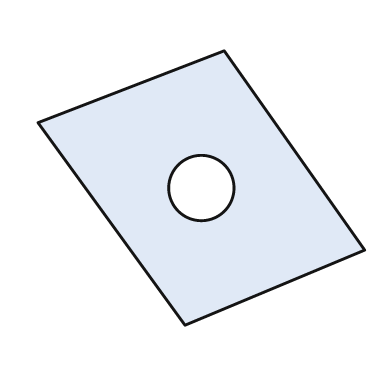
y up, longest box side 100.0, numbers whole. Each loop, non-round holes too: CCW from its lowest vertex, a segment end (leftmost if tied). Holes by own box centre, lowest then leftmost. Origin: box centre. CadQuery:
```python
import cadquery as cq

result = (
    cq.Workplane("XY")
    .moveTo(-5.0, -42.0)
    .lineTo(50.0, -19.0)
    .lineTo(7.0, 42.0)
    .lineTo(-50.0, 20.0)
    .close()
    .moveTo(0.0, 0.0)
    .circle(10.0)
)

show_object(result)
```